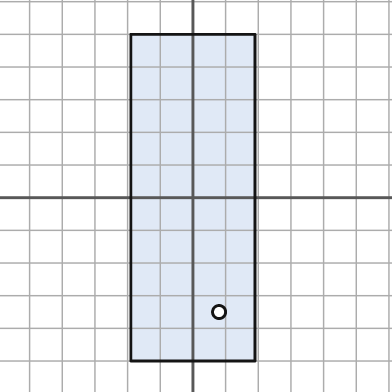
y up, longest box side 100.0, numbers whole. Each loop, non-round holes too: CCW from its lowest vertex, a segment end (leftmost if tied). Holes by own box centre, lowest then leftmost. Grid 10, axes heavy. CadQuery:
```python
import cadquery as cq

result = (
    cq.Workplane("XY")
    .moveTo(-19.0, -50.0)
    .lineTo(19.0, -50.0)
    .lineTo(19.0, 50.0)
    .lineTo(-19.0, 50.0)
    .close()
    .moveTo(8.0, -35.0)
    .circle(2.0)
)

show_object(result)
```